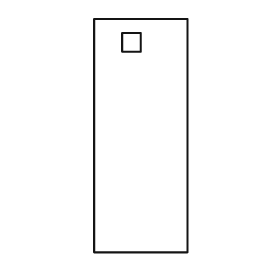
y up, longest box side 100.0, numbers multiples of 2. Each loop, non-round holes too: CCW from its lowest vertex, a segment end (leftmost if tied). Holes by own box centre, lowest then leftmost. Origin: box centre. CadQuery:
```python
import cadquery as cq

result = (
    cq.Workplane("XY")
    .moveTo(-20.0, -50.0)
    .lineTo(20.0, -50.0)
    .lineTo(20.0, 50.0)
    .lineTo(-20.0, 50.0)
    .close()
    .moveTo(-8.0, 36.0)
    .lineTo(0.0, 36.0)
    .lineTo(0.0, 44.0)
    .lineTo(-8.0, 44.0)
    .close()
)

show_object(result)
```